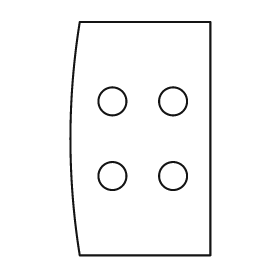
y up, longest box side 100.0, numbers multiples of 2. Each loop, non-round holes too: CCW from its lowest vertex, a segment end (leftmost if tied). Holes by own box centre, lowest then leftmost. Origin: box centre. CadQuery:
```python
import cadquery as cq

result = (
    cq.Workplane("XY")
    .moveTo(-26.0, -50.0)
    .lineTo(30.0, -50.0)
    .lineTo(30.0, 50.0)
    .lineTo(-26.0, 50.0)
    .threePointArc((-30.0, 0.0), (-26.0, -50.0))
    .close()
    .moveTo(-12.0, -16.0)
    .circle(6.0)
    .moveTo(14.0, -16.0)
    .circle(6.0)
    .moveTo(-12.0, 16.0)
    .circle(6.0)
    .moveTo(14.0, 16.0)
    .circle(6.0)
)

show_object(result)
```